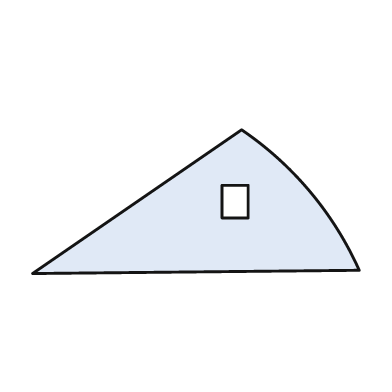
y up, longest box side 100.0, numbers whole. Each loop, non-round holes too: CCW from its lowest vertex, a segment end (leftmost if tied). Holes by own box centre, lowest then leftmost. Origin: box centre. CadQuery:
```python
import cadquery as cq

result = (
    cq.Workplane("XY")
    .moveTo(-50.0, -22.0)
    .lineTo(50.0, -21.0)
    .threePointArc((35.0, 3.0), (14.0, 22.0))
    .close()
    .moveTo(8.0, -5.0)
    .lineTo(16.0, -5.0)
    .lineTo(16.0, 5.0)
    .lineTo(8.0, 5.0)
    .close()
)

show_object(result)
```